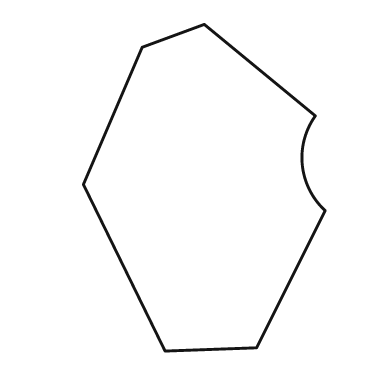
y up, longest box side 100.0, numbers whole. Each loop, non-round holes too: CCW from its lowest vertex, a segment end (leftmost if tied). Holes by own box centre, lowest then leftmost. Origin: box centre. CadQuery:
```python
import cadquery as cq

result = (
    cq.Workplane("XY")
    .moveTo(-12.0, -50.0)
    .lineTo(16.0, -49.0)
    .lineTo(37.0, -7.0)
    .threePointArc((30.0, 7.0), (34.0, 22.0))
    .lineTo(0.0, 50.0)
    .lineTo(-19.0, 43.0)
    .lineTo(-37.0, 1.0)
    .close()
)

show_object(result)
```